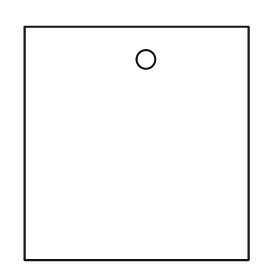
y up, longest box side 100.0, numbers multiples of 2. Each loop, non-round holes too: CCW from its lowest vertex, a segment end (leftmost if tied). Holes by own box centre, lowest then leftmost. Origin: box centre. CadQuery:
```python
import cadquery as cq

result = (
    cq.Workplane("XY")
    .moveTo(-48.0, -50.0)
    .lineTo(48.0, -50.0)
    .lineTo(48.0, 50.0)
    .lineTo(-48.0, 50.0)
    .close()
    .moveTo(4.0, 36.0)
    .circle(4.0)
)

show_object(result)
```